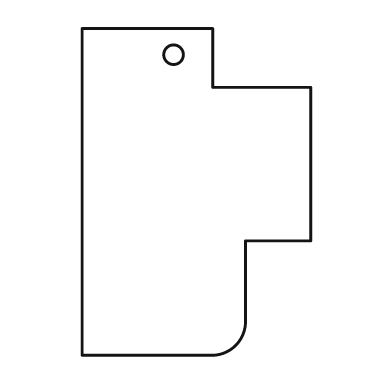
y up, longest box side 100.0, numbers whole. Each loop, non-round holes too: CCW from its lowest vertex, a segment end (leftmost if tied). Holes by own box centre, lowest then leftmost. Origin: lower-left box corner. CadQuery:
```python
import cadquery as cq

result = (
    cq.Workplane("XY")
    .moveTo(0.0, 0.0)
    .lineTo(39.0, 0.0)
    .threePointArc((47.0, 3.0), (50.0, 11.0))
    .lineTo(50.0, 35.0)
    .lineTo(70.0, 35.0)
    .lineTo(70.0, 82.0)
    .lineTo(40.0, 82.0)
    .lineTo(40.0, 100.0)
    .lineTo(0.0, 100.0)
    .close()
    .moveTo(28.0, 92.0)
    .circle(3.0)
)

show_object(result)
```